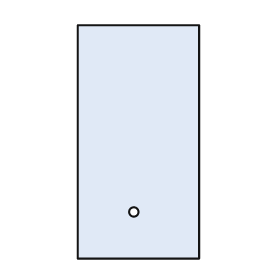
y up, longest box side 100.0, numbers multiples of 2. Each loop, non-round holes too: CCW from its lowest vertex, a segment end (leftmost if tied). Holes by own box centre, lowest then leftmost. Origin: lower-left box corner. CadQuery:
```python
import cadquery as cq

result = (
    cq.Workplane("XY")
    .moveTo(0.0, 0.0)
    .lineTo(52.0, 0.0)
    .lineTo(52.0, 100.0)
    .lineTo(0.0, 100.0)
    .close()
    .moveTo(24.0, 20.0)
    .circle(2.0)
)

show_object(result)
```